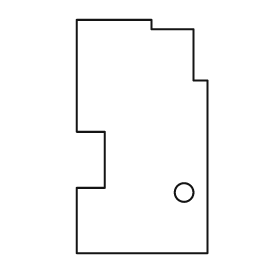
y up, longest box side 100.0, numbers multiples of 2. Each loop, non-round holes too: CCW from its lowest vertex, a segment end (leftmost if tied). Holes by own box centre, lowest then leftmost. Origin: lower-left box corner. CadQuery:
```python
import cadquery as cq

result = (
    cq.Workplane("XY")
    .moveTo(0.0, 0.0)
    .lineTo(56.0, 0.0)
    .lineTo(56.0, 74.0)
    .lineTo(50.0, 74.0)
    .lineTo(50.0, 96.0)
    .lineTo(32.0, 96.0)
    .lineTo(32.0, 100.0)
    .lineTo(0.0, 100.0)
    .lineTo(0.0, 52.0)
    .lineTo(12.0, 52.0)
    .lineTo(12.0, 28.0)
    .lineTo(0.0, 28.0)
    .close()
    .moveTo(46.0, 26.0)
    .circle(4.0)
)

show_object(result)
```